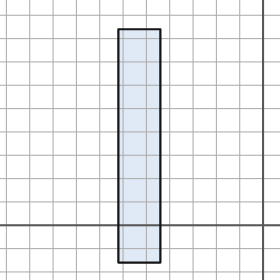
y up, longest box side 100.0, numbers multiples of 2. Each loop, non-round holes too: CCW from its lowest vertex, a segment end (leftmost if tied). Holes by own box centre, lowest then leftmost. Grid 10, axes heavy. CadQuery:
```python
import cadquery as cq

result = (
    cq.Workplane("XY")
    .moveTo(-62.0, -16.0)
    .lineTo(-44.0, -16.0)
    .lineTo(-44.0, 84.0)
    .lineTo(-62.0, 84.0)
    .close()
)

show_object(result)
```